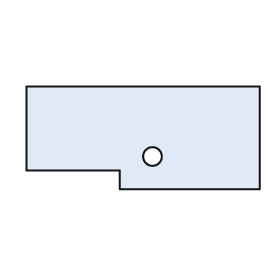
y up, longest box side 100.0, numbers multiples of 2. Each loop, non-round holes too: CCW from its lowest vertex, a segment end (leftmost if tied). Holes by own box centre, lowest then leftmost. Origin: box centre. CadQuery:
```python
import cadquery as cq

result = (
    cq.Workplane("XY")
    .moveTo(-10.0, -22.0)
    .lineTo(50.0, -22.0)
    .lineTo(50.0, 22.0)
    .lineTo(-50.0, 22.0)
    .lineTo(-50.0, -14.0)
    .lineTo(-10.0, -14.0)
    .close()
    .moveTo(4.0, -8.0)
    .circle(4.0)
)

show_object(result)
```